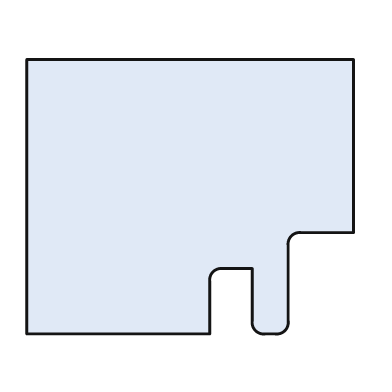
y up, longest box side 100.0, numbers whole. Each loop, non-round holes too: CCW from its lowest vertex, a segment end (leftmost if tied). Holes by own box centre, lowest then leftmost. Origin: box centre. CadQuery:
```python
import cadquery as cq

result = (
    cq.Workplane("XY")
    .moveTo(-50.0, -42.0)
    .lineTo(6.0, -42.0)
    .lineTo(6.0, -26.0)
    .threePointArc((7.0, -23.0), (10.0, -22.0))
    .lineTo(19.0, -22.0)
    .lineTo(19.0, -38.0)
    .threePointArc((20.0, -41.0), (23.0, -42.0))
    .lineTo(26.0, -42.0)
    .threePointArc((29.0, -41.0), (30.0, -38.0))
    .lineTo(30.0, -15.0)
    .threePointArc((31.0, -12.0), (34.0, -11.0))
    .lineTo(50.0, -11.0)
    .lineTo(50.0, 42.0)
    .lineTo(-50.0, 42.0)
    .close()
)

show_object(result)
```